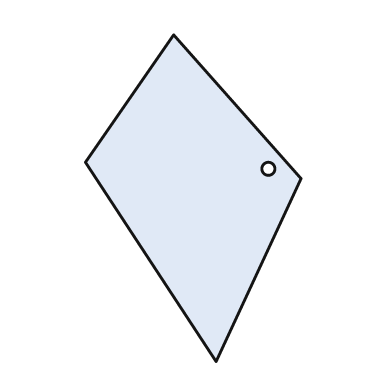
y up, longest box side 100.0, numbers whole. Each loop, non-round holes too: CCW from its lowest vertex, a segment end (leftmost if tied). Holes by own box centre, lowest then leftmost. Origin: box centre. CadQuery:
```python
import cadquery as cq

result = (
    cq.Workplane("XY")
    .moveTo(7.0, -50.0)
    .lineTo(33.0, 6.0)
    .lineTo(-6.0, 50.0)
    .lineTo(-33.0, 11.0)
    .close()
    .moveTo(23.0, 9.0)
    .circle(2.0)
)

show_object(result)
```